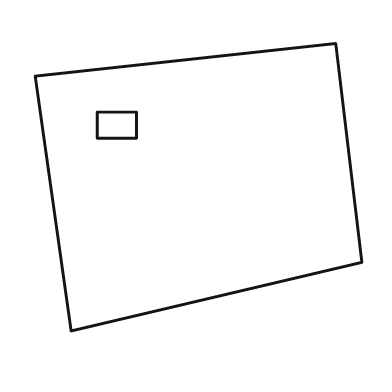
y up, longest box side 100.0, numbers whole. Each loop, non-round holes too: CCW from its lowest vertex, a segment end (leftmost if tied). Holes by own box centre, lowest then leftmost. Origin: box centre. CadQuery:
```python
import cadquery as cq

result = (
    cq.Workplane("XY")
    .moveTo(-39.0, -44.0)
    .lineTo(50.0, -23.0)
    .lineTo(42.0, 44.0)
    .lineTo(-50.0, 34.0)
    .close()
    .moveTo(-31.0, 15.0)
    .lineTo(-19.0, 15.0)
    .lineTo(-19.0, 23.0)
    .lineTo(-31.0, 23.0)
    .close()
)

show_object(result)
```